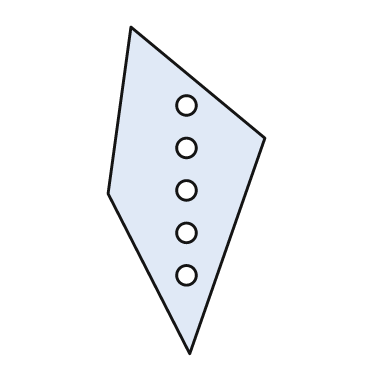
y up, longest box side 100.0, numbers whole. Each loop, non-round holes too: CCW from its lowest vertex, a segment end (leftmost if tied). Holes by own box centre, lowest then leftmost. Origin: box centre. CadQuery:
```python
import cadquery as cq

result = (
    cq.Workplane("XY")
    .moveTo(1.0, -50.0)
    .lineTo(24.0, 16.0)
    .lineTo(-17.0, 50.0)
    .lineTo(-24.0, -1.0)
    .close()
    .moveTo(0.0, -26.0)
    .circle(3.0)
    .moveTo(0.0, -13.0)
    .circle(3.0)
    .moveTo(0.0, 0.0)
    .circle(3.0)
    .moveTo(0.0, 13.0)
    .circle(3.0)
    .moveTo(0.0, 26.0)
    .circle(3.0)
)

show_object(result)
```